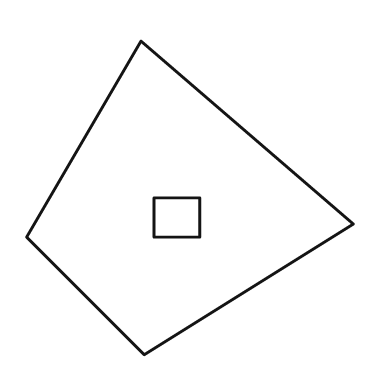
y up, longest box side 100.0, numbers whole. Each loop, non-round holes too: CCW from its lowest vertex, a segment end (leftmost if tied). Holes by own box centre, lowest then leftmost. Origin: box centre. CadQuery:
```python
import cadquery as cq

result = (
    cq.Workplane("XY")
    .moveTo(-14.0, -48.0)
    .lineTo(50.0, -8.0)
    .lineTo(-15.0, 48.0)
    .lineTo(-50.0, -12.0)
    .close()
    .moveTo(-11.0, -12.0)
    .lineTo(3.0, -12.0)
    .lineTo(3.0, 0.0)
    .lineTo(-11.0, 0.0)
    .close()
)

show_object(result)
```